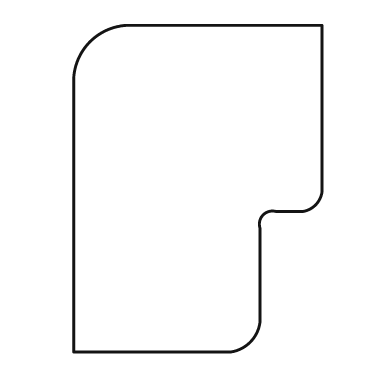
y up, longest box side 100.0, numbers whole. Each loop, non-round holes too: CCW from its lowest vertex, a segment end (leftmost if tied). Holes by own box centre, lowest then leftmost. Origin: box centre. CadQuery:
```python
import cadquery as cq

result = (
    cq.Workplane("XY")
    .moveTo(-38.0, -50.0)
    .lineTo(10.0, -50.0)
    .threePointArc((16.0, -47.0), (19.0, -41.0))
    .lineTo(19.0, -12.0)
    .threePointArc((20.0, -8.0), (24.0, -7.0))
    .lineTo(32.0, -7.0)
    .threePointArc((36.0, -5.0), (38.0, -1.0))
    .lineTo(38.0, 50.0)
    .lineTo(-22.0, 50.0)
    .threePointArc((-33.0, 45.0), (-38.0, 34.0))
    .close()
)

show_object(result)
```